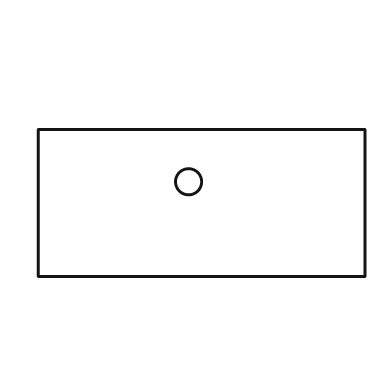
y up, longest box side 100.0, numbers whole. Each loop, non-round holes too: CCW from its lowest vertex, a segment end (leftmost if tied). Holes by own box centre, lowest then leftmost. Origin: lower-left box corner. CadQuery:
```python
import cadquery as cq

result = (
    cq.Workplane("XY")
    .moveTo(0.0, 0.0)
    .lineTo(100.0, 0.0)
    .lineTo(100.0, 45.0)
    .lineTo(0.0, 45.0)
    .close()
    .moveTo(46.0, 29.0)
    .circle(4.0)
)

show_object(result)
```